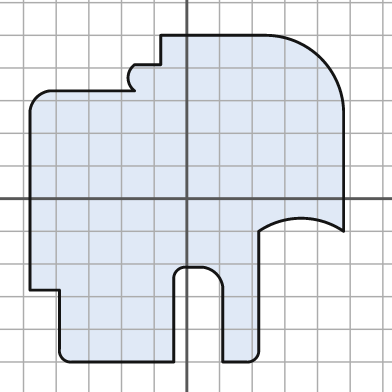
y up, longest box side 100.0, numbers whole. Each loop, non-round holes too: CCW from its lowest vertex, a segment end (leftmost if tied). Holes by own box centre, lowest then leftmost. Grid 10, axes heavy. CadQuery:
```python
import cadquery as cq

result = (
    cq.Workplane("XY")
    .moveTo(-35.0, -50.0)
    .lineTo(-4.0, -50.0)
    .lineTo(-4.0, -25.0)
    .threePointArc((-3.0, -22.0), (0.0, -21.0))
    .lineTo(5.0, -21.0)
    .threePointArc((9.0, -23.0), (11.0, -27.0))
    .lineTo(11.0, -50.0)
    .lineTo(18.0, -50.0)
    .threePointArc((21.0, -49.0), (22.0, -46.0))
    .lineTo(22.0, -10.0)
    .threePointArc((35.0, -6.0), (48.0, -10.0))
    .lineTo(48.0, 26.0)
    .threePointArc((41.0, 43.0), (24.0, 50.0))
    .lineTo(-8.0, 50.0)
    .lineTo(-8.0, 41.0)
    .lineTo(-16.0, 41.0)
    .threePointArc((-18.0, 37.0), (-16.0, 33.0))
    .lineTo(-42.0, 33.0)
    .threePointArc((-46.0, 31.0), (-48.0, 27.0))
    .lineTo(-48.0, -28.0)
    .lineTo(-39.0, -28.0)
    .lineTo(-39.0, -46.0)
    .threePointArc((-38.0, -49.0), (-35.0, -50.0))
    .close()
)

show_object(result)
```